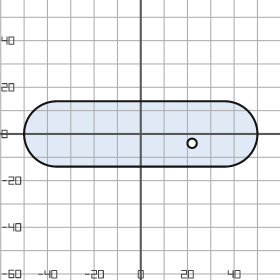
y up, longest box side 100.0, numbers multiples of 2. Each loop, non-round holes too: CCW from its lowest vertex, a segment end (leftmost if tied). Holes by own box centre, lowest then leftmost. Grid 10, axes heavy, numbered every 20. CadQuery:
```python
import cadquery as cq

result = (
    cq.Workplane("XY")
    .moveTo(-36.0, -14.0)
    .lineTo(36.0, -14.0)
    .threePointArc((50.0, 0.0), (36.0, 14.0))
    .lineTo(-36.0, 14.0)
    .threePointArc((-50.0, 0.0), (-36.0, -14.0))
    .close()
    .moveTo(22.0, -4.0)
    .circle(2.0)
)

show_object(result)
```